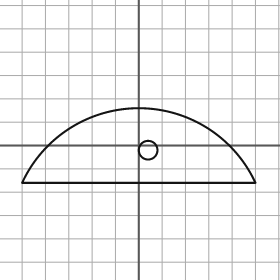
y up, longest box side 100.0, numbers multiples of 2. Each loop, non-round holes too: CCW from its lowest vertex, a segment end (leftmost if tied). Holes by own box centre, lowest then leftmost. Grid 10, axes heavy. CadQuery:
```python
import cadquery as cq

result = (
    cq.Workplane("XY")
    .moveTo(-50.0, -16.0)
    .lineTo(50.0, -16.0)
    .threePointArc((0.0, 16.0), (-50.0, -16.0))
    .close()
    .moveTo(4.0, -2.0)
    .circle(4.0)
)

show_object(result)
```